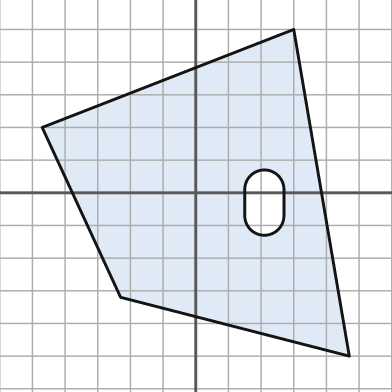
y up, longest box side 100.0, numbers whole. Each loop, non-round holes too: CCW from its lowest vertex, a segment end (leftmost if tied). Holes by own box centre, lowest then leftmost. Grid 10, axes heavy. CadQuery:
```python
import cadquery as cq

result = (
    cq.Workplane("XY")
    .moveTo(47.0, -50.0)
    .lineTo(30.0, 50.0)
    .lineTo(-47.0, 20.0)
    .lineTo(-23.0, -32.0)
    .close()
    .moveTo(15.0, -7.0)
    .threePointArc((21.0, -13.0), (27.0, -7.0))
    .lineTo(27.0, 1.0)
    .threePointArc((21.0, 7.0), (15.0, 1.0))
    .close()
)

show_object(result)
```